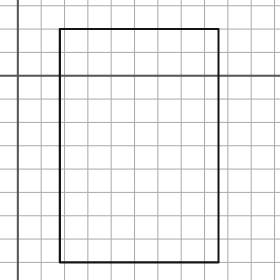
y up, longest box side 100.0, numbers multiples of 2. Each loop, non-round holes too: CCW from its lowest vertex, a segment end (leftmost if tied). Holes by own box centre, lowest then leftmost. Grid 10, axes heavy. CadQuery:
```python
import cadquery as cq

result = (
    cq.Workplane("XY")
    .moveTo(18.0, -80.0)
    .lineTo(86.0, -80.0)
    .lineTo(86.0, 20.0)
    .lineTo(18.0, 20.0)
    .close()
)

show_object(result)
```